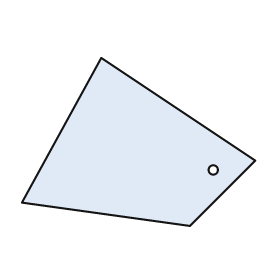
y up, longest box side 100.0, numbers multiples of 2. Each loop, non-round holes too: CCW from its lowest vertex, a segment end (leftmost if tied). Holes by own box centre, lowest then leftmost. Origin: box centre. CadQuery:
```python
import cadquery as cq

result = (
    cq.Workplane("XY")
    .moveTo(22.0, -36.0)
    .lineTo(50.0, -8.0)
    .lineTo(-16.0, 36.0)
    .lineTo(-50.0, -26.0)
    .close()
    .moveTo(32.0, -12.0)
    .circle(2.0)
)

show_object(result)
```